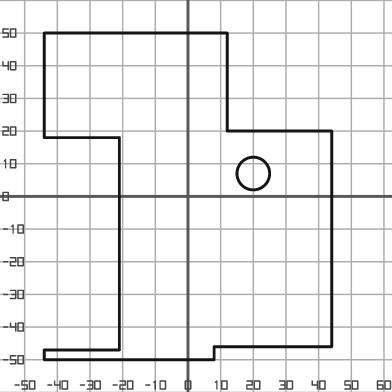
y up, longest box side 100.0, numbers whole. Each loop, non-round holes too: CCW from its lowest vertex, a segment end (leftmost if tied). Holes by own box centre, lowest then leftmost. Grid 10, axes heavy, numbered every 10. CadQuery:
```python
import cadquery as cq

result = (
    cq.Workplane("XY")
    .moveTo(-44.0, -50.0)
    .lineTo(8.0, -50.0)
    .lineTo(8.0, -46.0)
    .lineTo(44.0, -46.0)
    .lineTo(44.0, 20.0)
    .lineTo(12.0, 20.0)
    .lineTo(12.0, 50.0)
    .lineTo(-44.0, 50.0)
    .lineTo(-44.0, 18.0)
    .lineTo(-21.0, 18.0)
    .lineTo(-21.0, -47.0)
    .lineTo(-44.0, -47.0)
    .close()
    .moveTo(20.0, 7.0)
    .circle(5.0)
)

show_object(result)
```